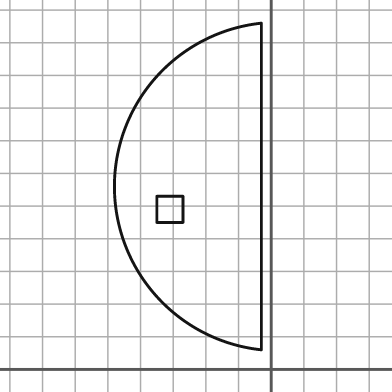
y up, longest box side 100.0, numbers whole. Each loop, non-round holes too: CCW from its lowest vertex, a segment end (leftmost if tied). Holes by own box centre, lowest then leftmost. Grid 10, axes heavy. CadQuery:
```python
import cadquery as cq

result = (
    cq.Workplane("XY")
    .moveTo(-3.0, 6.0)
    .lineTo(-3.0, 106.0)
    .threePointArc((-48.0, 56.0), (-3.0, 6.0))
    .close()
    .moveTo(-35.0, 45.0)
    .lineTo(-27.0, 45.0)
    .lineTo(-27.0, 53.0)
    .lineTo(-35.0, 53.0)
    .close()
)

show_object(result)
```